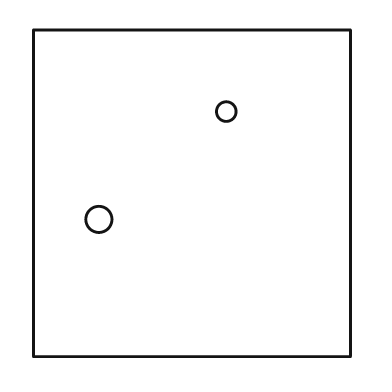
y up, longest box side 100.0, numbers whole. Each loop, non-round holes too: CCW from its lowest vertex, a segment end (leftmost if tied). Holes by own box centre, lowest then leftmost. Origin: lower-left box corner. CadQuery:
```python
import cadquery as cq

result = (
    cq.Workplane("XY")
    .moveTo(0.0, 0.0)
    .lineTo(97.0, 0.0)
    .lineTo(97.0, 100.0)
    .lineTo(0.0, 100.0)
    .close()
    .moveTo(20.0, 42.0)
    .circle(4.0)
    .moveTo(59.0, 75.0)
    .circle(3.0)
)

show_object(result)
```